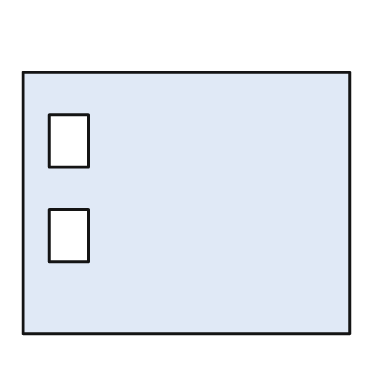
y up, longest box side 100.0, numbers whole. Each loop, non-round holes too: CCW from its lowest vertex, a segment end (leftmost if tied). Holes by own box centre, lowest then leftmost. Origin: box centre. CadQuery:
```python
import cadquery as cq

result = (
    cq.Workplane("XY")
    .moveTo(-50.0, -40.0)
    .lineTo(50.0, -40.0)
    .lineTo(50.0, 40.0)
    .lineTo(-50.0, 40.0)
    .close()
    .moveTo(-42.0, -18.0)
    .lineTo(-30.0, -18.0)
    .lineTo(-30.0, -2.0)
    .lineTo(-42.0, -2.0)
    .close()
    .moveTo(-42.0, 11.0)
    .lineTo(-30.0, 11.0)
    .lineTo(-30.0, 27.0)
    .lineTo(-42.0, 27.0)
    .close()
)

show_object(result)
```